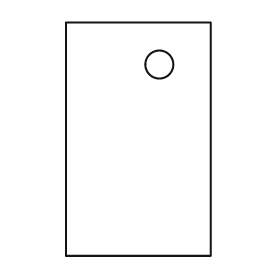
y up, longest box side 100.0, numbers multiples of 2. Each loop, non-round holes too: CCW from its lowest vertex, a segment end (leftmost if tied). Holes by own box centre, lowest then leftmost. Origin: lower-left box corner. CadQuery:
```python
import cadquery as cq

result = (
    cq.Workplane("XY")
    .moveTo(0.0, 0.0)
    .lineTo(62.0, 0.0)
    .lineTo(62.0, 100.0)
    .lineTo(0.0, 100.0)
    .close()
    .moveTo(40.0, 82.0)
    .circle(6.0)
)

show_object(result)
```